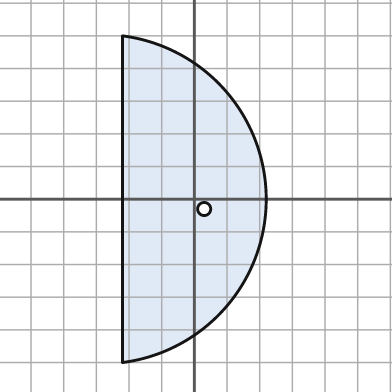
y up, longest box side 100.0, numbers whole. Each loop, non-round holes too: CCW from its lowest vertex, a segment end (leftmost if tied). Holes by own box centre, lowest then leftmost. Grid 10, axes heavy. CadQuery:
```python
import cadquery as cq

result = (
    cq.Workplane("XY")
    .moveTo(-22.0, -50.0)
    .threePointArc((22.0, 0.0), (-22.0, 50.0))
    .close()
    .moveTo(3.0, -3.0)
    .circle(2.0)
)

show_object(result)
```